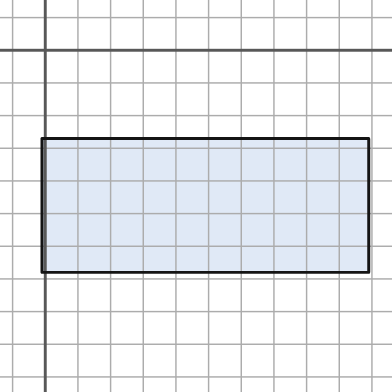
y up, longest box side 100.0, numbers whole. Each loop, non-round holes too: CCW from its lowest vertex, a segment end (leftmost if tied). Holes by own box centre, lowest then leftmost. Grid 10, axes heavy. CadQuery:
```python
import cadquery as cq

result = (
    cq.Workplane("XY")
    .moveTo(-1.0, -68.0)
    .lineTo(99.0, -68.0)
    .lineTo(99.0, -27.0)
    .lineTo(-1.0, -27.0)
    .close()
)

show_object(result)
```